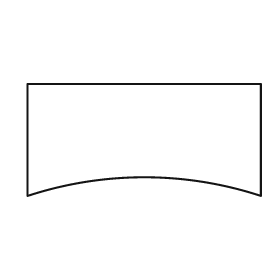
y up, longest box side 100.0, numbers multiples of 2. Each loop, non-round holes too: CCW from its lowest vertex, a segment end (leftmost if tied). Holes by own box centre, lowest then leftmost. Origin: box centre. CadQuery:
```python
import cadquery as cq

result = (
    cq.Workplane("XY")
    .moveTo(-50.0, -24.0)
    .threePointArc((0.0, -16.0), (50.0, -24.0))
    .lineTo(50.0, 24.0)
    .lineTo(-50.0, 24.0)
    .close()
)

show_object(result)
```